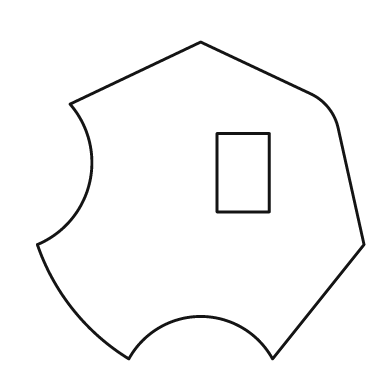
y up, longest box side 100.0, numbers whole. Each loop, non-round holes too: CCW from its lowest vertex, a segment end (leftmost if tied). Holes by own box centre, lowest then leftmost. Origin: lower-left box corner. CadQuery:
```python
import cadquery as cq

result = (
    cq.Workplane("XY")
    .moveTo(28.0, 0.0)
    .threePointArc((50.0, 13.0), (72.0, 0.0))
    .lineTo(100.0, 35.0)
    .lineTo(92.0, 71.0)
    .threePointArc((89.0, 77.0), (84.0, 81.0))
    .lineTo(50.0, 97.0)
    .lineTo(10.0, 78.0)
    .threePointArc((16.0, 54.0), (0.0, 35.0))
    .threePointArc((11.0, 15.0), (28.0, 0.0))
    .close()
    .moveTo(55.0, 45.0)
    .lineTo(71.0, 45.0)
    .lineTo(71.0, 69.0)
    .lineTo(55.0, 69.0)
    .close()
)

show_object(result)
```